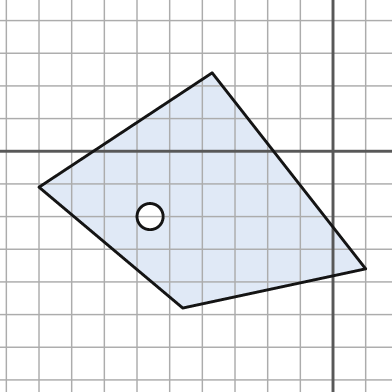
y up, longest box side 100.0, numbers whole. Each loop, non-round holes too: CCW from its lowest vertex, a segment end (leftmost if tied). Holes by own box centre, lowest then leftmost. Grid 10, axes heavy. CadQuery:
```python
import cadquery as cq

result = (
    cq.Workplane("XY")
    .moveTo(-46.0, -48.0)
    .lineTo(10.0, -36.0)
    .lineTo(-37.0, 24.0)
    .lineTo(-90.0, -11.0)
    .close()
    .moveTo(-56.0, -20.0)
    .circle(4.0)
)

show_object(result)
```